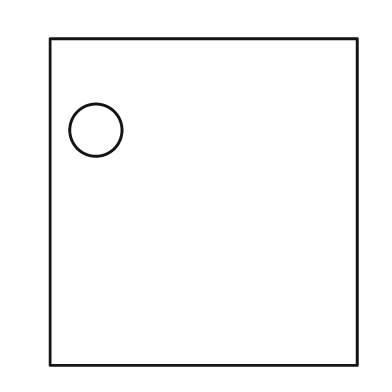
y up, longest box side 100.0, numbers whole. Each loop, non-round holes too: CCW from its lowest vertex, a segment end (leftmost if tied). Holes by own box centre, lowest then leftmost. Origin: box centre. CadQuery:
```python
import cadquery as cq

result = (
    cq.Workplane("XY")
    .moveTo(-47.0, -50.0)
    .lineTo(47.0, -50.0)
    .lineTo(47.0, 50.0)
    .lineTo(-47.0, 50.0)
    .close()
    .moveTo(-33.0, 22.0)
    .circle(8.0)
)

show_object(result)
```